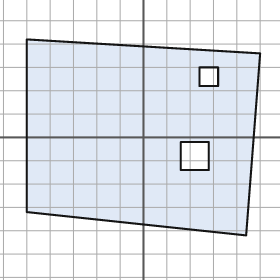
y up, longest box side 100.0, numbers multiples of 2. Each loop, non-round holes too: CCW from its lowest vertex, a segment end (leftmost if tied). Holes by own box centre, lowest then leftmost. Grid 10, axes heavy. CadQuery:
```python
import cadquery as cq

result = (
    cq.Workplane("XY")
    .moveTo(44.0, -42.0)
    .lineTo(50.0, 36.0)
    .lineTo(-50.0, 42.0)
    .lineTo(-50.0, -32.0)
    .close()
    .moveTo(16.0, -14.0)
    .lineTo(28.0, -14.0)
    .lineTo(28.0, -2.0)
    .lineTo(16.0, -2.0)
    .close()
    .moveTo(24.0, 22.0)
    .lineTo(32.0, 22.0)
    .lineTo(32.0, 30.0)
    .lineTo(24.0, 30.0)
    .close()
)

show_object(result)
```